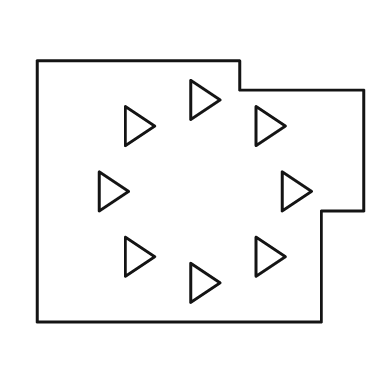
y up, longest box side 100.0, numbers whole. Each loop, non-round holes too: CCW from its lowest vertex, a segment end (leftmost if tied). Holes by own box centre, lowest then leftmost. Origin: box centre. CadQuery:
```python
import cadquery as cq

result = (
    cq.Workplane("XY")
    .moveTo(-50.0, -40.0)
    .lineTo(37.0, -40.0)
    .lineTo(37.0, -6.0)
    .lineTo(50.0, -6.0)
    .lineTo(50.0, 31.0)
    .lineTo(12.0, 31.0)
    .lineTo(12.0, 40.0)
    .lineTo(-50.0, 40.0)
    .close()
    .moveTo(-3.0, -34.0)
    .lineTo(6.0, -28.0)
    .lineTo(-3.0, -22.0)
    .close()
    .moveTo(-23.0, -26.0)
    .lineTo(-14.0, -20.0)
    .lineTo(-23.0, -14.0)
    .close()
    .moveTo(17.0, -26.0)
    .lineTo(26.0, -20.0)
    .lineTo(17.0, -14.0)
    .close()
    .moveTo(-31.0, -6.0)
    .lineTo(-22.0, 0.0)
    .lineTo(-31.0, 6.0)
    .close()
    .moveTo(25.0, -6.0)
    .lineTo(34.0, 0.0)
    .lineTo(25.0, 6.0)
    .close()
    .moveTo(-23.0, 14.0)
    .lineTo(-14.0, 20.0)
    .lineTo(-23.0, 26.0)
    .close()
    .moveTo(17.0, 14.0)
    .lineTo(26.0, 20.0)
    .lineTo(17.0, 26.0)
    .close()
    .moveTo(-3.0, 22.0)
    .lineTo(6.0, 28.0)
    .lineTo(-3.0, 34.0)
    .close()
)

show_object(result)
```